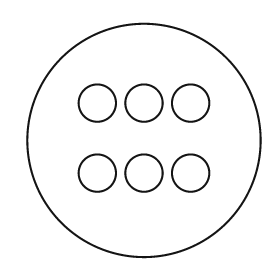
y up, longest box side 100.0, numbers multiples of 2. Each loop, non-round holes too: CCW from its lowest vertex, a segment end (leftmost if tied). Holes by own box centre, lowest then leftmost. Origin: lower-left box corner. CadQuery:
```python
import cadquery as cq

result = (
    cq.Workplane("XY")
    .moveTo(50.0, 50.0)
    .circle(50.0)
    .moveTo(30.0, 36.0)
    .circle(8.0)
    .moveTo(50.0, 36.0)
    .circle(8.0)
    .moveTo(70.0, 36.0)
    .circle(8.0)
    .moveTo(30.0, 66.0)
    .circle(8.0)
    .moveTo(50.0, 66.0)
    .circle(8.0)
    .moveTo(70.0, 66.0)
    .circle(8.0)
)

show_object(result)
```